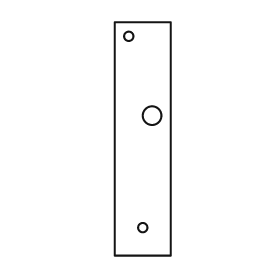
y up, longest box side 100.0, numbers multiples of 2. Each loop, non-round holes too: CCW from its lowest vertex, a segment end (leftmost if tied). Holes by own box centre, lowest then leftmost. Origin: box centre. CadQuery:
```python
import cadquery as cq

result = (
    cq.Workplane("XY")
    .moveTo(-12.0, -50.0)
    .lineTo(12.0, -50.0)
    .lineTo(12.0, 50.0)
    .lineTo(-12.0, 50.0)
    .close()
    .moveTo(0.0, -38.0)
    .circle(2.0)
    .moveTo(4.0, 10.0)
    .circle(4.0)
    .moveTo(-6.0, 44.0)
    .circle(2.0)
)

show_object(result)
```